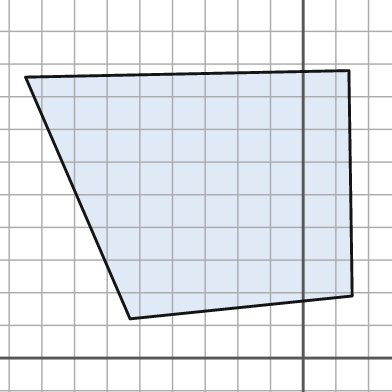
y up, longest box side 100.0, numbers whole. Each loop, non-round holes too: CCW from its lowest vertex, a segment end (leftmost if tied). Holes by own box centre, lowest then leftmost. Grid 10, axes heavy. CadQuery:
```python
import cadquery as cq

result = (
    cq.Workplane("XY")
    .moveTo(-53.0, 12.0)
    .lineTo(15.0, 19.0)
    .lineTo(14.0, 88.0)
    .lineTo(-85.0, 86.0)
    .close()
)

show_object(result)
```